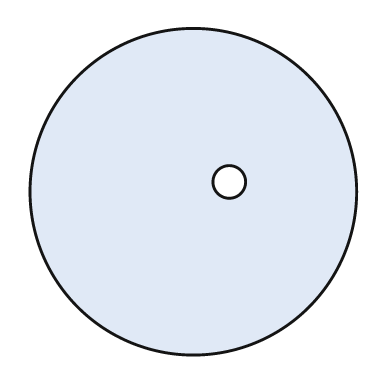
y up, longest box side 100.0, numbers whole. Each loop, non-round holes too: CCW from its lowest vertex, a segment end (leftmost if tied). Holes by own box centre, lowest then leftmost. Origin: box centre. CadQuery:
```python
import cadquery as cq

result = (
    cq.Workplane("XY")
    .moveTo(0.0, 0.0)
    .circle(50.0)
    .moveTo(11.0, 3.0)
    .circle(5.0)
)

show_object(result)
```